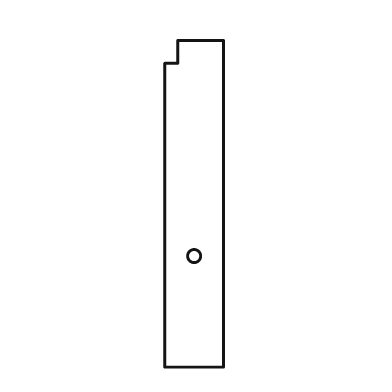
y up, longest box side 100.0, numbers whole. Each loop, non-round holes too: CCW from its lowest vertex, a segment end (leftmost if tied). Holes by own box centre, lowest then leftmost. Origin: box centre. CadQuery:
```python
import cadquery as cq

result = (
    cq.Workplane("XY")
    .moveTo(-9.0, -50.0)
    .lineTo(9.0, -50.0)
    .lineTo(9.0, 50.0)
    .lineTo(-5.0, 50.0)
    .lineTo(-5.0, 43.0)
    .lineTo(-9.0, 43.0)
    .close()
    .moveTo(0.0, -16.0)
    .circle(2.0)
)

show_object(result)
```